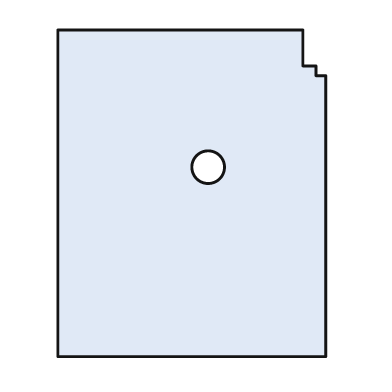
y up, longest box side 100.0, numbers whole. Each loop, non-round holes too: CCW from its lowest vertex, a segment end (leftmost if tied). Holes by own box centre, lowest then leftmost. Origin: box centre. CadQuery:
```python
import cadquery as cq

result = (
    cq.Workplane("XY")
    .moveTo(-41.0, -50.0)
    .lineTo(41.0, -50.0)
    .lineTo(41.0, 36.0)
    .lineTo(38.0, 36.0)
    .lineTo(38.0, 39.0)
    .lineTo(34.0, 39.0)
    .lineTo(34.0, 50.0)
    .lineTo(-41.0, 50.0)
    .close()
    .moveTo(5.0, 8.0)
    .circle(5.0)
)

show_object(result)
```